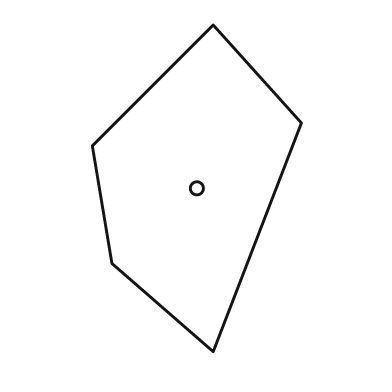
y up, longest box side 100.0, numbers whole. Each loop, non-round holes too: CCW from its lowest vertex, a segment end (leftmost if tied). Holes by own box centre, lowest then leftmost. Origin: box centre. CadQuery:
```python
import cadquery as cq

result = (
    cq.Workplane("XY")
    .moveTo(5.0, -50.0)
    .lineTo(32.0, 20.0)
    .lineTo(5.0, 50.0)
    .lineTo(-32.0, 13.0)
    .lineTo(-26.0, -23.0)
    .close()
    .moveTo(0.0, 0.0)
    .circle(2.0)
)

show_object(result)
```